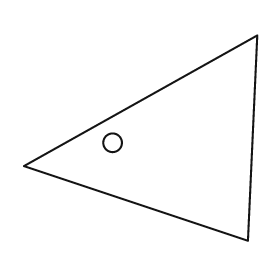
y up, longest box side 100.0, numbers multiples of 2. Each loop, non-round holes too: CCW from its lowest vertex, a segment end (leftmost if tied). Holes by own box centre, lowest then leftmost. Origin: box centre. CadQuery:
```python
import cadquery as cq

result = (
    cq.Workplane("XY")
    .moveTo(46.0, -44.0)
    .lineTo(50.0, 44.0)
    .lineTo(-50.0, -12.0)
    .close()
    .moveTo(-12.0, -2.0)
    .circle(4.0)
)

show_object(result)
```